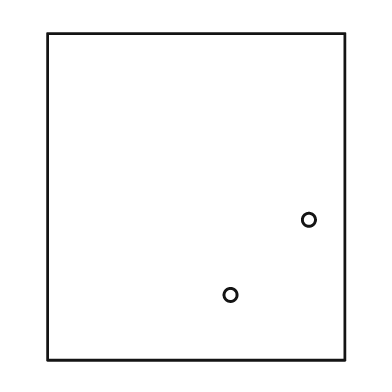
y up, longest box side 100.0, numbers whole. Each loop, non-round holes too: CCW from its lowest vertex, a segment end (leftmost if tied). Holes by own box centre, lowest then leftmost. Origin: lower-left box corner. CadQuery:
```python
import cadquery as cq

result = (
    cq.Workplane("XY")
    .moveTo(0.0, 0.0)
    .lineTo(91.0, 0.0)
    .lineTo(91.0, 100.0)
    .lineTo(0.0, 100.0)
    .close()
    .moveTo(56.0, 20.0)
    .circle(2.0)
    .moveTo(80.0, 43.0)
    .circle(2.0)
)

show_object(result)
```